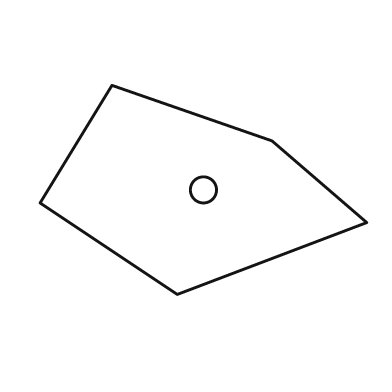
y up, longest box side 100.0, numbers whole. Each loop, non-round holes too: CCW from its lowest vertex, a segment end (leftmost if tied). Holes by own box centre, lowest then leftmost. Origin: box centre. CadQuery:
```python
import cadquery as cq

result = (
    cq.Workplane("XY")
    .moveTo(-8.0, -32.0)
    .lineTo(50.0, -10.0)
    .lineTo(21.0, 15.0)
    .lineTo(-28.0, 32.0)
    .lineTo(-50.0, -4.0)
    .close()
    .moveTo(0.0, 0.0)
    .circle(4.0)
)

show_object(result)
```